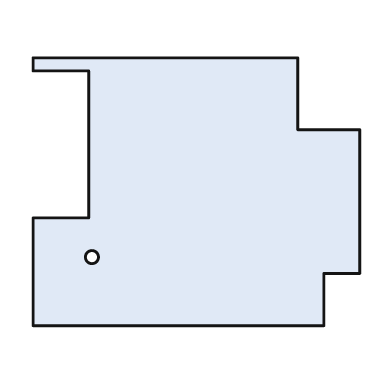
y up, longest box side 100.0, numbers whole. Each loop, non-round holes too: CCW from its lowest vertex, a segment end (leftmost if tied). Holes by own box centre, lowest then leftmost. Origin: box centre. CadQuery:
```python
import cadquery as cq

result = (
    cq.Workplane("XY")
    .moveTo(-50.0, -41.0)
    .lineTo(39.0, -41.0)
    .lineTo(39.0, -25.0)
    .lineTo(50.0, -25.0)
    .lineTo(50.0, 19.0)
    .lineTo(31.0, 19.0)
    .lineTo(31.0, 41.0)
    .lineTo(-50.0, 41.0)
    .lineTo(-50.0, 37.0)
    .lineTo(-33.0, 37.0)
    .lineTo(-33.0, -8.0)
    .lineTo(-50.0, -8.0)
    .close()
    .moveTo(-32.0, -20.0)
    .circle(2.0)
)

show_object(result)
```